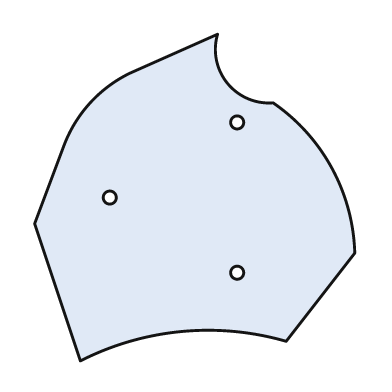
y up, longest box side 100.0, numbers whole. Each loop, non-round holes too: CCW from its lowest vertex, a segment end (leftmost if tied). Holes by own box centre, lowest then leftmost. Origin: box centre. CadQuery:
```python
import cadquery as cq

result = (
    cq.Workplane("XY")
    .moveTo(-35.0, -50.0)
    .threePointArc((-4.0, -41.0), (28.0, -44.0))
    .lineTo(49.0, -17.0)
    .threePointArc((42.0, 9.0), (24.0, 29.0))
    .threePointArc((10.0, 35.0), (7.0, 50.0))
    .lineTo(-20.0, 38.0)
    .threePointArc((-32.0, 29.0), (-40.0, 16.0))
    .lineTo(-49.0, -8.0)
    .close()
    .moveTo(13.0, -23.0)
    .circle(2.0)
    .moveTo(-26.0, 0.0)
    .circle(2.0)
    .moveTo(13.0, 23.0)
    .circle(2.0)
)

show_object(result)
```